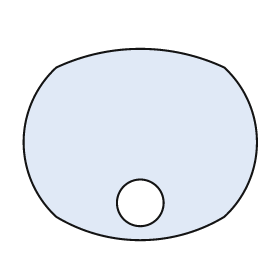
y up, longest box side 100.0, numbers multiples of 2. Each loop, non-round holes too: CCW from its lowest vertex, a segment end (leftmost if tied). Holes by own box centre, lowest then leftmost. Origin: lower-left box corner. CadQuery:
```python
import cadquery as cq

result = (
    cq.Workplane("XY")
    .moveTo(14.0, 10.0)
    .threePointArc((50.0, 0.0), (86.0, 10.0))
    .threePointArc((100.0, 42.0), (86.0, 74.0))
    .threePointArc((50.0, 82.0), (14.0, 74.0))
    .threePointArc((0.0, 42.0), (14.0, 10.0))
    .close()
    .moveTo(50.0, 16.0)
    .circle(10.0)
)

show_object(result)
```